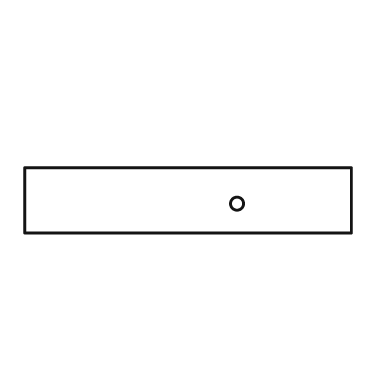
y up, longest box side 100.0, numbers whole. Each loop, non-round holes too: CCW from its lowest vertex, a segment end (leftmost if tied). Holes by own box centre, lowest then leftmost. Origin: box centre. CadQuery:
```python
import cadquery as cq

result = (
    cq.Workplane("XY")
    .moveTo(-50.0, -10.0)
    .lineTo(50.0, -10.0)
    .lineTo(50.0, 10.0)
    .lineTo(-50.0, 10.0)
    .close()
    .moveTo(15.0, -1.0)
    .circle(2.0)
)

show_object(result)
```